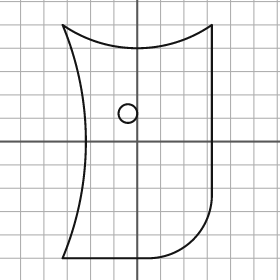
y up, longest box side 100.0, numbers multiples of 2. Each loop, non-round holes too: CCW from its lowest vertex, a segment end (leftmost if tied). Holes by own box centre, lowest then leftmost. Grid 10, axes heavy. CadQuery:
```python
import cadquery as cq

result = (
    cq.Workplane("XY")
    .moveTo(-32.0, -50.0)
    .lineTo(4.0, -50.0)
    .threePointArc((24.0, -42.0), (32.0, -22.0))
    .lineTo(32.0, 50.0)
    .threePointArc((0.0, 40.0), (-32.0, 50.0))
    .threePointArc((-22.0, 0.0), (-32.0, -50.0))
    .close()
    .moveTo(-4.0, 12.0)
    .circle(4.0)
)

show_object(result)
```